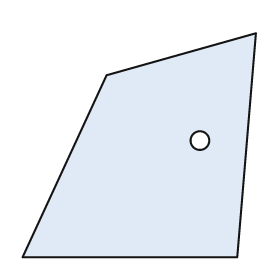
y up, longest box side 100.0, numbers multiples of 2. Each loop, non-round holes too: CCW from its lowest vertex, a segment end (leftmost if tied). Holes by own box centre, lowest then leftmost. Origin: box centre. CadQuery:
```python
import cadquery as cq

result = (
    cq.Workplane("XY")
    .moveTo(-50.0, -48.0)
    .lineTo(42.0, -48.0)
    .lineTo(50.0, 48.0)
    .lineTo(-14.0, 30.0)
    .close()
    .moveTo(26.0, 2.0)
    .circle(4.0)
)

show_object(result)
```